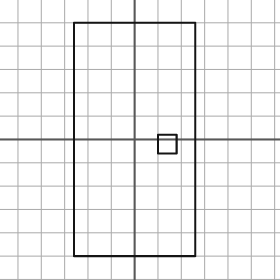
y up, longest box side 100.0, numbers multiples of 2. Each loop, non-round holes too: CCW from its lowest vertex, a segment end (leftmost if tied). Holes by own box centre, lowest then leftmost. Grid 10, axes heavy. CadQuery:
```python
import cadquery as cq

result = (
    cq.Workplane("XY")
    .moveTo(-26.0, -50.0)
    .lineTo(26.0, -50.0)
    .lineTo(26.0, 50.0)
    .lineTo(-26.0, 50.0)
    .close()
    .moveTo(10.0, -6.0)
    .lineTo(18.0, -6.0)
    .lineTo(18.0, 2.0)
    .lineTo(10.0, 2.0)
    .close()
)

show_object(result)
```